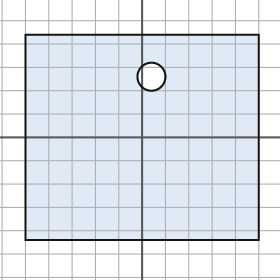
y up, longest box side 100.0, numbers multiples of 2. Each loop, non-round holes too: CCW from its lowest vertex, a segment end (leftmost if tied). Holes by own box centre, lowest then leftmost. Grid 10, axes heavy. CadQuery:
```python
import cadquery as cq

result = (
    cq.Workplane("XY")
    .moveTo(-50.0, -44.0)
    .lineTo(50.0, -44.0)
    .lineTo(50.0, 44.0)
    .lineTo(-50.0, 44.0)
    .close()
    .moveTo(4.0, 26.0)
    .circle(6.0)
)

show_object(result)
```